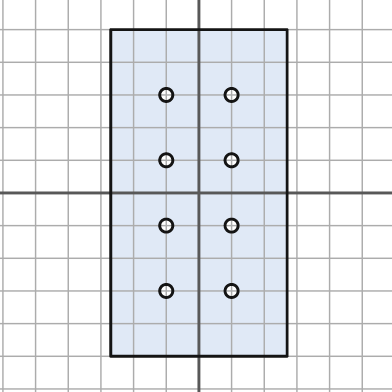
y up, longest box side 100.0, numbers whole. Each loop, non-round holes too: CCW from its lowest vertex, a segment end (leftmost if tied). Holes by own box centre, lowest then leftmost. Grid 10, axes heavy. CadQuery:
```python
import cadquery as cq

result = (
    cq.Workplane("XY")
    .moveTo(-27.0, -50.0)
    .lineTo(27.0, -50.0)
    .lineTo(27.0, 50.0)
    .lineTo(-27.0, 50.0)
    .close()
    .moveTo(-10.0, -30.0)
    .circle(2.0)
    .moveTo(10.0, -30.0)
    .circle(2.0)
    .moveTo(-10.0, -10.0)
    .circle(2.0)
    .moveTo(10.0, -10.0)
    .circle(2.0)
    .moveTo(-10.0, 10.0)
    .circle(2.0)
    .moveTo(10.0, 10.0)
    .circle(2.0)
    .moveTo(-10.0, 30.0)
    .circle(2.0)
    .moveTo(10.0, 30.0)
    .circle(2.0)
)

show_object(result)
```